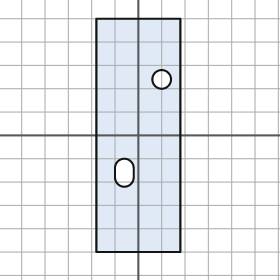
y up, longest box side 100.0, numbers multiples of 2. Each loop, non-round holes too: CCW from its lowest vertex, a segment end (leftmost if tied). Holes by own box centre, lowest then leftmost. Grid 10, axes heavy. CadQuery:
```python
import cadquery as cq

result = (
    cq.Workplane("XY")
    .moveTo(-18.0, -50.0)
    .lineTo(18.0, -50.0)
    .lineTo(18.0, 50.0)
    .lineTo(-18.0, 50.0)
    .close()
    .moveTo(-10.0, -18.0)
    .threePointArc((-6.0, -22.0), (-2.0, -18.0))
    .lineTo(-2.0, -14.0)
    .threePointArc((-6.0, -10.0), (-10.0, -14.0))
    .close()
    .moveTo(10.0, 24.0)
    .circle(4.0)
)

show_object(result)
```